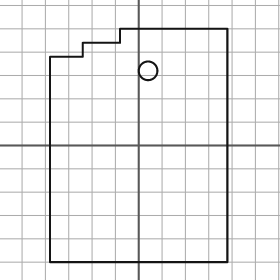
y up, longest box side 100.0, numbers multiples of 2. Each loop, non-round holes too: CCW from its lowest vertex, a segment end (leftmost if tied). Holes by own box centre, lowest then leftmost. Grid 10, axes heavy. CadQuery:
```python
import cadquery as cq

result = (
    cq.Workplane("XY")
    .moveTo(-38.0, -50.0)
    .lineTo(38.0, -50.0)
    .lineTo(38.0, 50.0)
    .lineTo(-8.0, 50.0)
    .lineTo(-8.0, 44.0)
    .lineTo(-24.0, 44.0)
    .lineTo(-24.0, 38.0)
    .lineTo(-38.0, 38.0)
    .close()
    .moveTo(4.0, 32.0)
    .circle(4.0)
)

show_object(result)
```